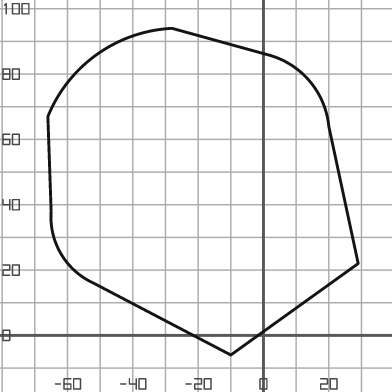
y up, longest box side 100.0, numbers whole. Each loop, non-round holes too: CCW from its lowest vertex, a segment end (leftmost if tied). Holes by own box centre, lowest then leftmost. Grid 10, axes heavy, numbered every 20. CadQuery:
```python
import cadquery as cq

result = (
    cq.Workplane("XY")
    .moveTo(-10.0, -6.0)
    .lineTo(29.0, 22.0)
    .lineTo(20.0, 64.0)
    .threePointArc((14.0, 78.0), (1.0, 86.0))
    .lineTo(-28.0, 94.0)
    .threePointArc((-51.0, 86.0), (-66.0, 67.0))
    .lineTo(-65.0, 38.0)
    .threePointArc((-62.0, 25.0), (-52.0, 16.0))
    .close()
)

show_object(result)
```